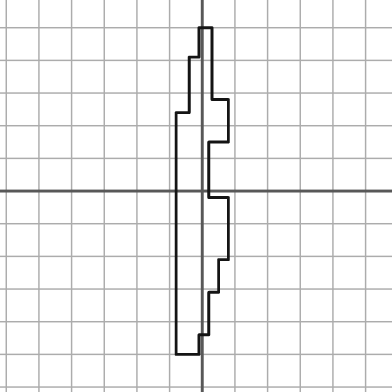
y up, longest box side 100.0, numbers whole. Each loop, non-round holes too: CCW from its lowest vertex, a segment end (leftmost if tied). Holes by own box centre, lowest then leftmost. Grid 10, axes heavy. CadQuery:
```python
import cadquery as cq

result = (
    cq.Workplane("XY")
    .moveTo(-8.0, -50.0)
    .lineTo(-1.0, -50.0)
    .lineTo(-1.0, -44.0)
    .lineTo(2.0, -44.0)
    .lineTo(2.0, -31.0)
    .lineTo(5.0, -31.0)
    .lineTo(5.0, -21.0)
    .lineTo(8.0, -21.0)
    .lineTo(8.0, -2.0)
    .lineTo(2.0, -2.0)
    .lineTo(2.0, 15.0)
    .lineTo(8.0, 15.0)
    .lineTo(8.0, 28.0)
    .lineTo(3.0, 28.0)
    .lineTo(3.0, 50.0)
    .lineTo(-1.0, 50.0)
    .lineTo(-1.0, 41.0)
    .lineTo(-4.0, 41.0)
    .lineTo(-4.0, 24.0)
    .lineTo(-8.0, 24.0)
    .close()
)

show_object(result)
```